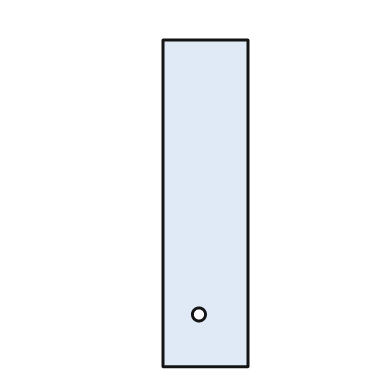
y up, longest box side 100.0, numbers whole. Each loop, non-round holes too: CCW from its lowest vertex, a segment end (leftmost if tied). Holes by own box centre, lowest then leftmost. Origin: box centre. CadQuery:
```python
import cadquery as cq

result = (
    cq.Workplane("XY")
    .moveTo(-13.0, -50.0)
    .lineTo(13.0, -50.0)
    .lineTo(13.0, 50.0)
    .lineTo(-13.0, 50.0)
    .close()
    .moveTo(-2.0, -34.0)
    .circle(2.0)
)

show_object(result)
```